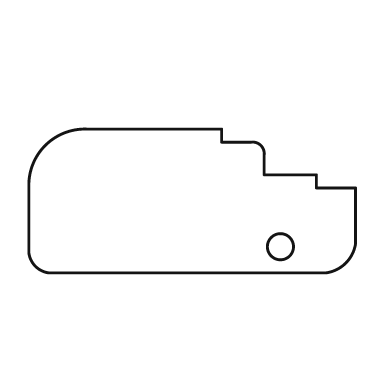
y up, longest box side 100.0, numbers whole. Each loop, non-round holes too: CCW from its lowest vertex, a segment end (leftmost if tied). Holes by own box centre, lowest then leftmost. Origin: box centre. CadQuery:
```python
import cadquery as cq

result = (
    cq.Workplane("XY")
    .moveTo(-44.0, -22.0)
    .lineTo(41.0, -22.0)
    .threePointArc((47.0, -19.0), (50.0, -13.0))
    .lineTo(50.0, 4.0)
    .lineTo(38.0, 4.0)
    .lineTo(38.0, 8.0)
    .lineTo(22.0, 8.0)
    .lineTo(22.0, 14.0)
    .threePointArc((21.0, 17.0), (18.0, 18.0))
    .lineTo(9.0, 18.0)
    .lineTo(9.0, 22.0)
    .lineTo(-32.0, 22.0)
    .threePointArc((-45.0, 17.0), (-50.0, 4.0))
    .lineTo(-50.0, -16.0)
    .threePointArc((-48.0, -20.0), (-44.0, -22.0))
    .close()
    .moveTo(27.0, -14.0)
    .circle(4.0)
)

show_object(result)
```